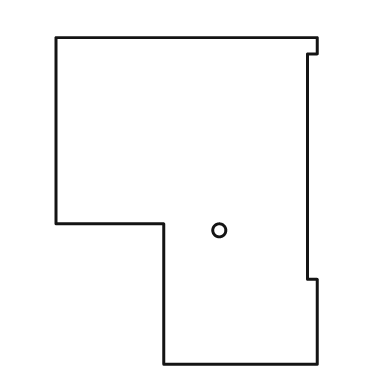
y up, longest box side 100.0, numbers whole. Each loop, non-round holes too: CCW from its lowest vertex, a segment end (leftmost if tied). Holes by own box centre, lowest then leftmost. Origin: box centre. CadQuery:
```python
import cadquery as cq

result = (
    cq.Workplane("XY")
    .moveTo(-7.0, -50.0)
    .lineTo(40.0, -50.0)
    .lineTo(40.0, -24.0)
    .lineTo(37.0, -24.0)
    .lineTo(37.0, 45.0)
    .lineTo(40.0, 45.0)
    .lineTo(40.0, 50.0)
    .lineTo(-40.0, 50.0)
    .lineTo(-40.0, -7.0)
    .lineTo(-7.0, -7.0)
    .close()
    .moveTo(10.0, -9.0)
    .circle(2.0)
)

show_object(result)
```